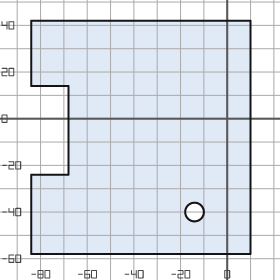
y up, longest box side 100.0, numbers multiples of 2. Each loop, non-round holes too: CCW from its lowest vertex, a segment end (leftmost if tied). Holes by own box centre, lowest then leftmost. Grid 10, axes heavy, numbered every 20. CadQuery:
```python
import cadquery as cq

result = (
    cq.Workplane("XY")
    .moveTo(-84.0, -58.0)
    .lineTo(10.0, -58.0)
    .lineTo(10.0, 42.0)
    .lineTo(-84.0, 42.0)
    .lineTo(-84.0, 14.0)
    .lineTo(-68.0, 14.0)
    .lineTo(-68.0, -24.0)
    .lineTo(-84.0, -24.0)
    .close()
    .moveTo(-14.0, -40.0)
    .circle(4.0)
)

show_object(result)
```